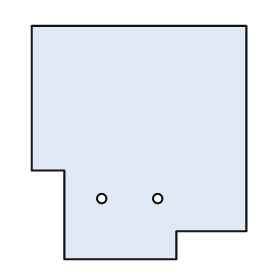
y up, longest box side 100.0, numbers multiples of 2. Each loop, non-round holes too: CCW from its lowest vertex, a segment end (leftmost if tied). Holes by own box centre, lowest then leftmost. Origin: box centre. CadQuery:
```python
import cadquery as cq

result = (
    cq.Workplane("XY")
    .moveTo(-32.0, -50.0)
    .lineTo(16.0, -50.0)
    .lineTo(16.0, -38.0)
    .lineTo(46.0, -38.0)
    .lineTo(46.0, 50.0)
    .lineTo(-46.0, 50.0)
    .lineTo(-46.0, -12.0)
    .lineTo(-32.0, -12.0)
    .close()
    .moveTo(-16.0, -24.0)
    .circle(2.0)
    .moveTo(8.0, -24.0)
    .circle(2.0)
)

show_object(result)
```